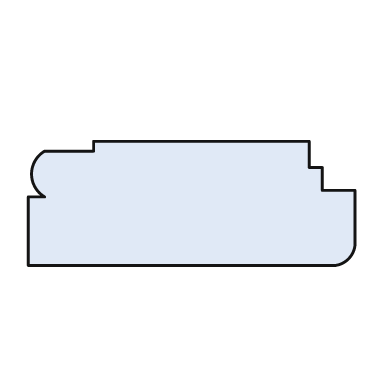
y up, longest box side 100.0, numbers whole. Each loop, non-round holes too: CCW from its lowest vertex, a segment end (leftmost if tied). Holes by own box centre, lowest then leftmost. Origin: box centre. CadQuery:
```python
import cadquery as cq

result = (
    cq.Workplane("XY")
    .moveTo(-50.0, -19.0)
    .lineTo(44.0, -19.0)
    .threePointArc((48.0, -17.0), (50.0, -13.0))
    .lineTo(50.0, 4.0)
    .lineTo(40.0, 4.0)
    .lineTo(40.0, 11.0)
    .lineTo(36.0, 11.0)
    .lineTo(36.0, 19.0)
    .lineTo(-30.0, 19.0)
    .lineTo(-30.0, 16.0)
    .lineTo(-45.0, 16.0)
    .threePointArc((-49.0, 9.0), (-45.0, 2.0))
    .lineTo(-50.0, 2.0)
    .close()
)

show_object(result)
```